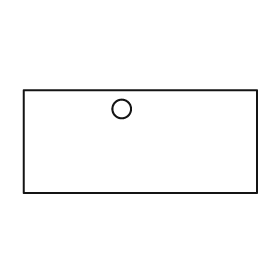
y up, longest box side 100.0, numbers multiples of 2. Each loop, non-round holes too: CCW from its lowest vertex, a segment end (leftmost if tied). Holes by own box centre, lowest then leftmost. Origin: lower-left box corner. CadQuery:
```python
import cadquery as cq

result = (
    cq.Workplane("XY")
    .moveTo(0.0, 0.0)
    .lineTo(100.0, 0.0)
    .lineTo(100.0, 44.0)
    .lineTo(0.0, 44.0)
    .close()
    .moveTo(42.0, 36.0)
    .circle(4.0)
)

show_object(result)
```